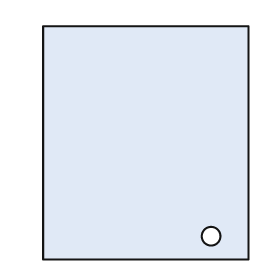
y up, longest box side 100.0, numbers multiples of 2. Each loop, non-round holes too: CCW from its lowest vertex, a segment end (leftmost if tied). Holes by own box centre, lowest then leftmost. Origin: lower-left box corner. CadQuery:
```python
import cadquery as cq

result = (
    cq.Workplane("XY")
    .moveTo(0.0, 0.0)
    .lineTo(88.0, 0.0)
    .lineTo(88.0, 100.0)
    .lineTo(0.0, 100.0)
    .close()
    .moveTo(72.0, 10.0)
    .circle(4.0)
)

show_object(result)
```